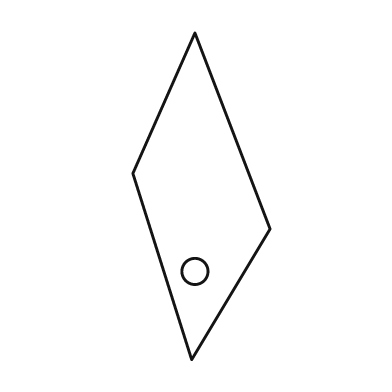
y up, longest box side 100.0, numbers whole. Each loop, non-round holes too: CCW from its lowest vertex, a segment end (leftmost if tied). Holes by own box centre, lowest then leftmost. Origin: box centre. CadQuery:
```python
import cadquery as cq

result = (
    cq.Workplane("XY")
    .moveTo(-3.0, -50.0)
    .lineTo(21.0, -10.0)
    .lineTo(-2.0, 50.0)
    .lineTo(-21.0, 7.0)
    .close()
    .moveTo(-2.0, -23.0)
    .circle(4.0)
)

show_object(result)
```